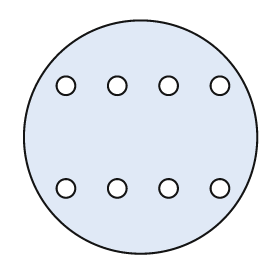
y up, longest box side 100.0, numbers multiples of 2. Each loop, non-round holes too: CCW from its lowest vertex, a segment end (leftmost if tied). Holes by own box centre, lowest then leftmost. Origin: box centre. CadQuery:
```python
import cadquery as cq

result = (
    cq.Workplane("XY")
    .moveTo(0.0, 0.0)
    .circle(50.0)
    .moveTo(-32.0, -22.0)
    .circle(4.0)
    .moveTo(-10.0, -22.0)
    .circle(4.0)
    .moveTo(12.0, -22.0)
    .circle(4.0)
    .moveTo(34.0, -22.0)
    .circle(4.0)
    .moveTo(-32.0, 22.0)
    .circle(4.0)
    .moveTo(-10.0, 22.0)
    .circle(4.0)
    .moveTo(12.0, 22.0)
    .circle(4.0)
    .moveTo(34.0, 22.0)
    .circle(4.0)
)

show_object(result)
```